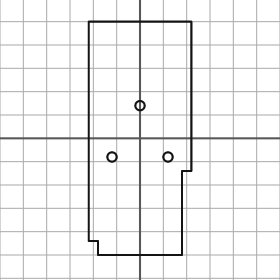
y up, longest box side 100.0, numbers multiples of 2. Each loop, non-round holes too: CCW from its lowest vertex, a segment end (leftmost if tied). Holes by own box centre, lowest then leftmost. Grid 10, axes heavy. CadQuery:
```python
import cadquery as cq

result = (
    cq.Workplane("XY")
    .moveTo(-18.0, -50.0)
    .lineTo(18.0, -50.0)
    .lineTo(18.0, -14.0)
    .lineTo(22.0, -14.0)
    .lineTo(22.0, 50.0)
    .lineTo(-22.0, 50.0)
    .lineTo(-22.0, -44.0)
    .lineTo(-18.0, -44.0)
    .close()
    .moveTo(-12.0, -8.0)
    .circle(2.0)
    .moveTo(12.0, -8.0)
    .circle(2.0)
    .moveTo(0.0, 14.0)
    .circle(2.0)
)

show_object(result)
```